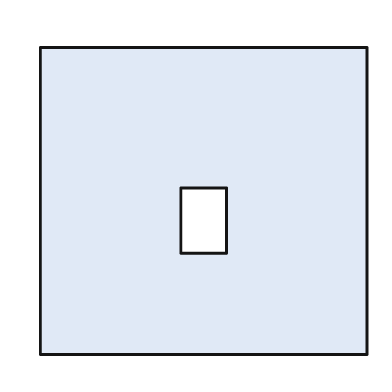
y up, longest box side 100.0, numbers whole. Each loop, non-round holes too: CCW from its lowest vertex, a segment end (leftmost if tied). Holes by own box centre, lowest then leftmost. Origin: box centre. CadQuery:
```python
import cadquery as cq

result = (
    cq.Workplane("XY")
    .moveTo(-50.0, -47.0)
    .lineTo(50.0, -47.0)
    .lineTo(50.0, 47.0)
    .lineTo(-50.0, 47.0)
    .close()
    .moveTo(-7.0, -16.0)
    .lineTo(7.0, -16.0)
    .lineTo(7.0, 4.0)
    .lineTo(-7.0, 4.0)
    .close()
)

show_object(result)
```